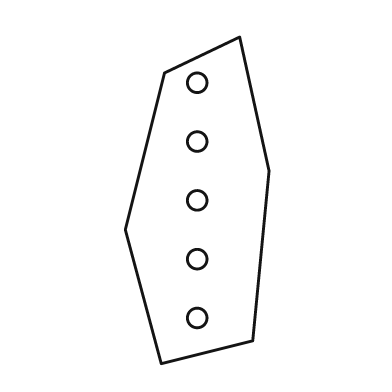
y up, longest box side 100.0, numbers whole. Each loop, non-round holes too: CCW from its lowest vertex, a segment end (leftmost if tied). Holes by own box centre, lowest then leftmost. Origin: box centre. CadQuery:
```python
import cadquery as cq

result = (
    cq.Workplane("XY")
    .moveTo(-11.0, -50.0)
    .lineTo(17.0, -43.0)
    .lineTo(22.0, 9.0)
    .lineTo(13.0, 50.0)
    .lineTo(-10.0, 39.0)
    .lineTo(-22.0, -9.0)
    .close()
    .moveTo(0.0, -36.0)
    .circle(3.0)
    .moveTo(0.0, -18.0)
    .circle(3.0)
    .moveTo(0.0, 0.0)
    .circle(3.0)
    .moveTo(0.0, 18.0)
    .circle(3.0)
    .moveTo(0.0, 36.0)
    .circle(3.0)
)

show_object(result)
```